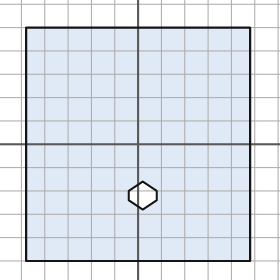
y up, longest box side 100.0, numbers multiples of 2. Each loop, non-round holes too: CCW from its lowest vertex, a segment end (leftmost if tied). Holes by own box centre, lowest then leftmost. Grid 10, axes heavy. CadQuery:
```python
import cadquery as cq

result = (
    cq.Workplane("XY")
    .moveTo(-48.0, -50.0)
    .lineTo(48.0, -50.0)
    .lineTo(48.0, 50.0)
    .lineTo(-48.0, 50.0)
    .close()
    .moveTo(2.0, -28.0)
    .lineTo(8.0, -24.0)
    .lineTo(8.0, -20.0)
    .lineTo(2.0, -16.0)
    .lineTo(-4.0, -20.0)
    .lineTo(-4.0, -24.0)
    .close()
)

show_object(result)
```